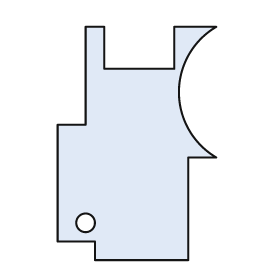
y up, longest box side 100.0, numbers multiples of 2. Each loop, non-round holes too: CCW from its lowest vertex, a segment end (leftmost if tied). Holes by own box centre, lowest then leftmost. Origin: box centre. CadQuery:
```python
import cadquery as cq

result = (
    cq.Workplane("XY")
    .moveTo(-18.0, -50.0)
    .lineTo(22.0, -50.0)
    .lineTo(22.0, -6.0)
    .lineTo(34.0, -6.0)
    .threePointArc((18.0, 22.0), (34.0, 50.0))
    .lineTo(16.0, 50.0)
    .lineTo(16.0, 32.0)
    .lineTo(-14.0, 32.0)
    .lineTo(-14.0, 50.0)
    .lineTo(-22.0, 50.0)
    .lineTo(-22.0, 8.0)
    .lineTo(-34.0, 8.0)
    .lineTo(-34.0, -42.0)
    .lineTo(-18.0, -42.0)
    .close()
    .moveTo(-22.0, -34.0)
    .circle(4.0)
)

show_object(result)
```